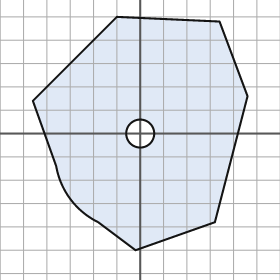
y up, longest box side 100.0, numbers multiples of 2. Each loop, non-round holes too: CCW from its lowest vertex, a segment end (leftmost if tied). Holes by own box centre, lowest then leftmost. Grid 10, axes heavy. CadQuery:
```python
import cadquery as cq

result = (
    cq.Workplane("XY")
    .moveTo(-2.0, -50.0)
    .lineTo(32.0, -38.0)
    .lineTo(46.0, 16.0)
    .lineTo(34.0, 48.0)
    .lineTo(-10.0, 50.0)
    .lineTo(-46.0, 14.0)
    .lineTo(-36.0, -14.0)
    .threePointArc((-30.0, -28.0), (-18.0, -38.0))
    .close()
    .moveTo(0.0, 0.0)
    .circle(6.0)
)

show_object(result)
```